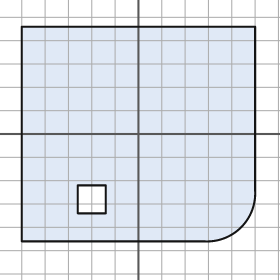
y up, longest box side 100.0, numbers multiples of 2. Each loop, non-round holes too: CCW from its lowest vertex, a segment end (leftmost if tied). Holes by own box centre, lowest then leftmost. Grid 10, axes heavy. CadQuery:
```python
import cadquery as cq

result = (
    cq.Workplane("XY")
    .moveTo(-50.0, -46.0)
    .lineTo(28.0, -46.0)
    .threePointArc((44.0, -40.0), (50.0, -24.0))
    .lineTo(50.0, 46.0)
    .lineTo(-50.0, 46.0)
    .close()
    .moveTo(-26.0, -34.0)
    .lineTo(-14.0, -34.0)
    .lineTo(-14.0, -22.0)
    .lineTo(-26.0, -22.0)
    .close()
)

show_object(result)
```